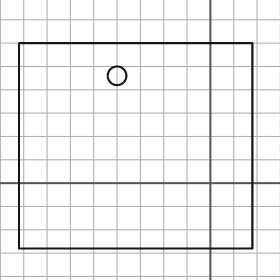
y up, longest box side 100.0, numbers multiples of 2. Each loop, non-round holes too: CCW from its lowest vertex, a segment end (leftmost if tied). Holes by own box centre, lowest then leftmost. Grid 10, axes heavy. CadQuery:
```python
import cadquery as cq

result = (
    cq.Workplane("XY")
    .moveTo(-82.0, -28.0)
    .lineTo(18.0, -28.0)
    .lineTo(18.0, 60.0)
    .lineTo(-82.0, 60.0)
    .close()
    .moveTo(-40.0, 46.0)
    .circle(4.0)
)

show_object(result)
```